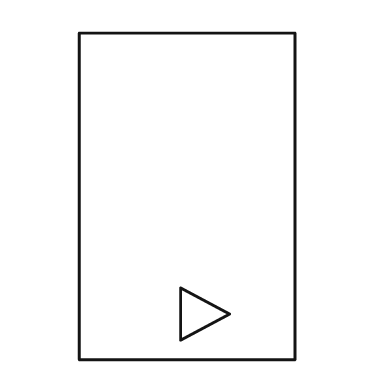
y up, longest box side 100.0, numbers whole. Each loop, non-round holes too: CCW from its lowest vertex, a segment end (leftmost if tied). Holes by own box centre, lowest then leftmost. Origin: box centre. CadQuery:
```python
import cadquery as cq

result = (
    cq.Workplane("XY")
    .moveTo(-33.0, -50.0)
    .lineTo(33.0, -50.0)
    .lineTo(33.0, 50.0)
    .lineTo(-33.0, 50.0)
    .close()
    .moveTo(-2.0, -44.0)
    .lineTo(13.0, -36.0)
    .lineTo(-2.0, -28.0)
    .close()
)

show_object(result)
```